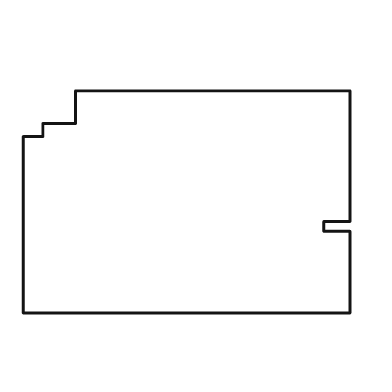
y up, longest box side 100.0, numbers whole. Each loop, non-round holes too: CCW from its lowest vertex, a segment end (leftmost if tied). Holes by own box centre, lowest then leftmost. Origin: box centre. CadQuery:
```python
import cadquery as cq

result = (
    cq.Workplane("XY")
    .moveTo(-50.0, -34.0)
    .lineTo(50.0, -34.0)
    .lineTo(50.0, -9.0)
    .lineTo(42.0, -9.0)
    .lineTo(42.0, -6.0)
    .lineTo(50.0, -6.0)
    .lineTo(50.0, 34.0)
    .lineTo(-34.0, 34.0)
    .lineTo(-34.0, 24.0)
    .lineTo(-44.0, 24.0)
    .lineTo(-44.0, 20.0)
    .lineTo(-50.0, 20.0)
    .close()
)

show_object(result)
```